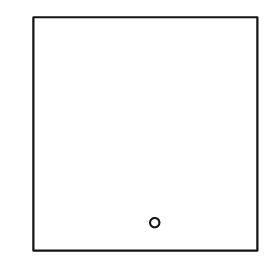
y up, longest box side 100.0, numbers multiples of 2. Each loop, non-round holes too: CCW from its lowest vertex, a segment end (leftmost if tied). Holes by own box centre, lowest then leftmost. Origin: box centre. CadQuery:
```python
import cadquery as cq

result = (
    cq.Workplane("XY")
    .moveTo(-48.0, -50.0)
    .lineTo(48.0, -50.0)
    .lineTo(48.0, 50.0)
    .lineTo(-48.0, 50.0)
    .close()
    .moveTo(4.0, -38.0)
    .circle(2.0)
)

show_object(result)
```